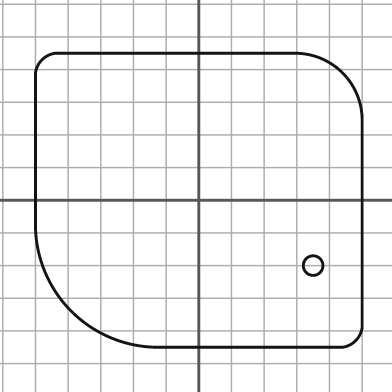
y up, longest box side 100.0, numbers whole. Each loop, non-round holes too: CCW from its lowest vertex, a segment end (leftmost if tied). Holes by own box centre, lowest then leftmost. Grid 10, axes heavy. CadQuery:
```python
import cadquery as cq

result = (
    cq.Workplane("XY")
    .moveTo(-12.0, -45.0)
    .lineTo(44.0, -45.0)
    .threePointArc((48.0, -43.0), (50.0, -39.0))
    .lineTo(50.0, 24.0)
    .threePointArc((44.0, 39.0), (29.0, 45.0))
    .lineTo(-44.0, 45.0)
    .threePointArc((-48.0, 43.0), (-50.0, 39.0))
    .lineTo(-50.0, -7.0)
    .threePointArc((-39.0, -34.0), (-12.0, -45.0))
    .close()
    .moveTo(35.0, -20.0)
    .circle(3.0)
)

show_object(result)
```